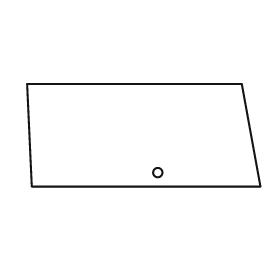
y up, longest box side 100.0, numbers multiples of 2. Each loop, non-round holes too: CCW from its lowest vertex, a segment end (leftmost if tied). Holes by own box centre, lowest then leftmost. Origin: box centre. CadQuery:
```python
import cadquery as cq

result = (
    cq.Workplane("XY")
    .moveTo(-48.0, -22.0)
    .lineTo(50.0, -22.0)
    .lineTo(42.0, 22.0)
    .lineTo(-50.0, 22.0)
    .close()
    .moveTo(6.0, -16.0)
    .circle(2.0)
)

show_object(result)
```